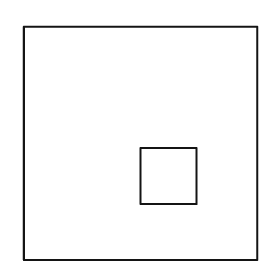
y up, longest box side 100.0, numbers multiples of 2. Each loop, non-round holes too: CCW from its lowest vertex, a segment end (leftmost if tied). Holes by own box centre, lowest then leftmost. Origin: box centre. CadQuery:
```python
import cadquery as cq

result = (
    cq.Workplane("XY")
    .moveTo(-50.0, -50.0)
    .lineTo(50.0, -50.0)
    .lineTo(50.0, 50.0)
    .lineTo(-50.0, 50.0)
    .close()
    .moveTo(0.0, -26.0)
    .lineTo(24.0, -26.0)
    .lineTo(24.0, -2.0)
    .lineTo(0.0, -2.0)
    .close()
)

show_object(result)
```